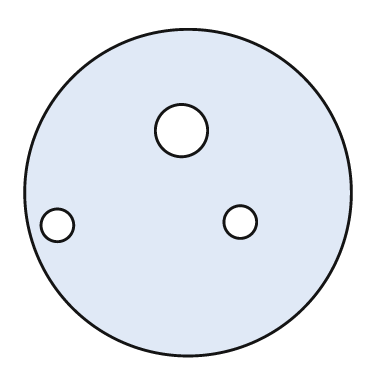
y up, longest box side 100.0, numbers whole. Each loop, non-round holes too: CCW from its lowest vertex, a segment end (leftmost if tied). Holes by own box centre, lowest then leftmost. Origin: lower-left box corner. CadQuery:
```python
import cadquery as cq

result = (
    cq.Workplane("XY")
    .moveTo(50.0, 50.0)
    .circle(50.0)
    .moveTo(10.0, 40.0)
    .circle(5.0)
    .moveTo(66.0, 41.0)
    .circle(5.0)
    .moveTo(48.0, 69.0)
    .circle(8.0)
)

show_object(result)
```